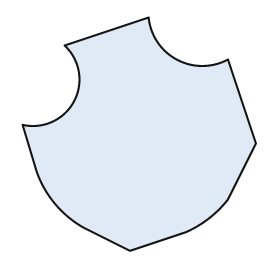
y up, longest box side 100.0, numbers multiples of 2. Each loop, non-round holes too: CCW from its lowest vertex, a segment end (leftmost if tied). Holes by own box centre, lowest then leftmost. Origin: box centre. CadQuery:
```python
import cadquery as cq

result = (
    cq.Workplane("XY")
    .moveTo(-4.0, -50.0)
    .lineTo(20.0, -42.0)
    .threePointArc((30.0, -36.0), (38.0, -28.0))
    .lineTo(50.0, -4.0)
    .lineTo(38.0, 32.0)
    .threePointArc((16.0, 32.0), (4.0, 50.0))
    .lineTo(-32.0, 38.0)
    .threePointArc((-28.0, 14.0), (-50.0, 4.0))
    .lineTo(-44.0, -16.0)
    .threePointArc((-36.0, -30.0), (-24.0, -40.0))
    .close()
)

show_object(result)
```